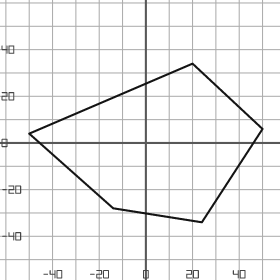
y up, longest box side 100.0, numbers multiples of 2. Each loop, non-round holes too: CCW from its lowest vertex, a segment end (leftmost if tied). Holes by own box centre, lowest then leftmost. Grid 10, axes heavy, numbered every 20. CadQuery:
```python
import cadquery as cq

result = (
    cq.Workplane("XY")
    .moveTo(24.0, -34.0)
    .lineTo(50.0, 6.0)
    .lineTo(20.0, 34.0)
    .lineTo(-50.0, 4.0)
    .lineTo(-14.0, -28.0)
    .close()
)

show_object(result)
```